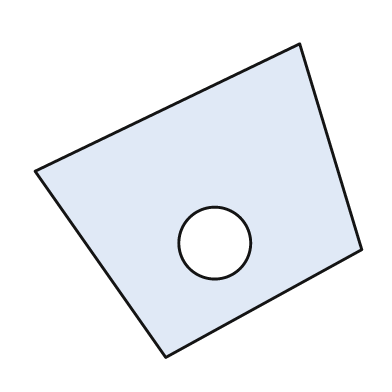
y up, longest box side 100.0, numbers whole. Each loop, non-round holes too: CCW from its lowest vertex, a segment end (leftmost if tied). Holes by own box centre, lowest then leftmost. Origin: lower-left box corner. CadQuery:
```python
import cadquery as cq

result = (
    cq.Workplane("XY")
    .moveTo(40.0, 0.0)
    .lineTo(100.0, 33.0)
    .lineTo(81.0, 96.0)
    .lineTo(0.0, 57.0)
    .close()
    .moveTo(55.0, 35.0)
    .circle(11.0)
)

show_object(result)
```